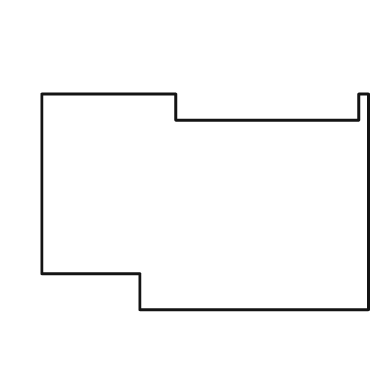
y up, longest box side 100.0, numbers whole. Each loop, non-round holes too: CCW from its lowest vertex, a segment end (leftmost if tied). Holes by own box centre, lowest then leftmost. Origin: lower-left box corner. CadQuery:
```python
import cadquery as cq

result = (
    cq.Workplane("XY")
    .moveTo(30.0, 0.0)
    .lineTo(100.0, 0.0)
    .lineTo(100.0, 66.0)
    .lineTo(97.0, 66.0)
    .lineTo(97.0, 58.0)
    .lineTo(41.0, 58.0)
    .lineTo(41.0, 66.0)
    .lineTo(0.0, 66.0)
    .lineTo(0.0, 11.0)
    .lineTo(30.0, 11.0)
    .close()
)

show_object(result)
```